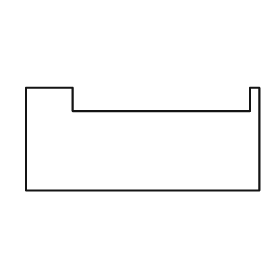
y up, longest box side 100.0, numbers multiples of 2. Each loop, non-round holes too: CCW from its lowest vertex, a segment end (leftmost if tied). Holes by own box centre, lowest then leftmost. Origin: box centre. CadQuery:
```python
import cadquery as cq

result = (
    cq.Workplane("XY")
    .moveTo(-50.0, -22.0)
    .lineTo(50.0, -22.0)
    .lineTo(50.0, 22.0)
    .lineTo(46.0, 22.0)
    .lineTo(46.0, 12.0)
    .lineTo(-30.0, 12.0)
    .lineTo(-30.0, 22.0)
    .lineTo(-50.0, 22.0)
    .close()
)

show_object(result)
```